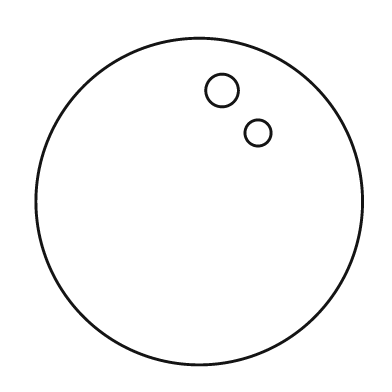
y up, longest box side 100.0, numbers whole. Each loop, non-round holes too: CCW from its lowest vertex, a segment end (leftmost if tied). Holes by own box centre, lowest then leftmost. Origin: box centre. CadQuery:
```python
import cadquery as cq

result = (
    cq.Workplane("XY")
    .moveTo(0.0, 0.0)
    .circle(50.0)
    .moveTo(18.0, 21.0)
    .circle(4.0)
    .moveTo(7.0, 34.0)
    .circle(5.0)
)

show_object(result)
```